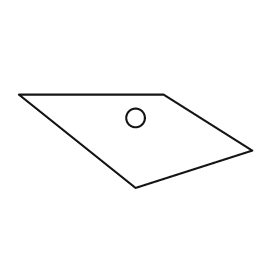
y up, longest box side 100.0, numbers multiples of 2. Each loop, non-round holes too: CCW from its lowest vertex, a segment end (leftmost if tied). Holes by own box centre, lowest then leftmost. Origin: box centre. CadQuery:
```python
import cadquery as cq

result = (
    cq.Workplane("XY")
    .moveTo(0.0, -20.0)
    .lineTo(50.0, -4.0)
    .lineTo(12.0, 20.0)
    .lineTo(-50.0, 20.0)
    .close()
    .moveTo(0.0, 10.0)
    .circle(4.0)
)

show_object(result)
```